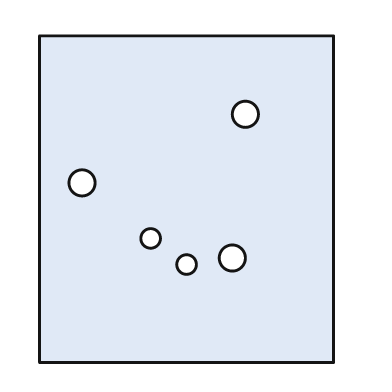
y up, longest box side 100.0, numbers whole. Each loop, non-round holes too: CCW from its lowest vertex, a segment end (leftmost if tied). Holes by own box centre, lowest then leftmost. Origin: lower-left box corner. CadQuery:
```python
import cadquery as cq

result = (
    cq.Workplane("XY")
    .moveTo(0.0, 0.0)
    .lineTo(90.0, 0.0)
    .lineTo(90.0, 100.0)
    .lineTo(0.0, 100.0)
    .close()
    .moveTo(45.0, 30.0)
    .circle(3.0)
    .moveTo(59.0, 32.0)
    .circle(4.0)
    .moveTo(34.0, 38.0)
    .circle(3.0)
    .moveTo(13.0, 55.0)
    .circle(4.0)
    .moveTo(63.0, 76.0)
    .circle(4.0)
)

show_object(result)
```